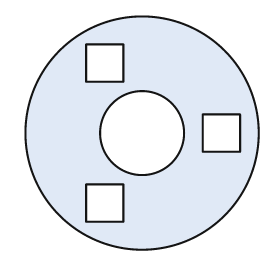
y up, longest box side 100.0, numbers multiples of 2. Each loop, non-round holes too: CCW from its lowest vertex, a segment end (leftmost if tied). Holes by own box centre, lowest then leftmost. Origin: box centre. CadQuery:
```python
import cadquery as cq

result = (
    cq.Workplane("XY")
    .moveTo(0.0, 0.0)
    .circle(50.0)
    .moveTo(-24.0, -38.0)
    .lineTo(-8.0, -38.0)
    .lineTo(-8.0, -22.0)
    .lineTo(-24.0, -22.0)
    .close()
    .moveTo(0.0, 0.0)
    .circle(18.0)
    .moveTo(26.0, -8.0)
    .lineTo(42.0, -8.0)
    .lineTo(42.0, 8.0)
    .lineTo(26.0, 8.0)
    .close()
    .moveTo(-24.0, 22.0)
    .lineTo(-8.0, 22.0)
    .lineTo(-8.0, 38.0)
    .lineTo(-24.0, 38.0)
    .close()
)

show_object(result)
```